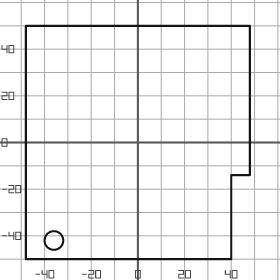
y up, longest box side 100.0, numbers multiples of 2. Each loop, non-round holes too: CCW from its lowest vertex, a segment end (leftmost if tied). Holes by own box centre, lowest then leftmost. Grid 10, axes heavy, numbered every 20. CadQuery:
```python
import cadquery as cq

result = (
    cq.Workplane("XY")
    .moveTo(-48.0, -50.0)
    .lineTo(40.0, -50.0)
    .lineTo(40.0, -14.0)
    .lineTo(48.0, -14.0)
    .lineTo(48.0, 50.0)
    .lineTo(-48.0, 50.0)
    .close()
    .moveTo(-36.0, -42.0)
    .circle(4.0)
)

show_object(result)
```